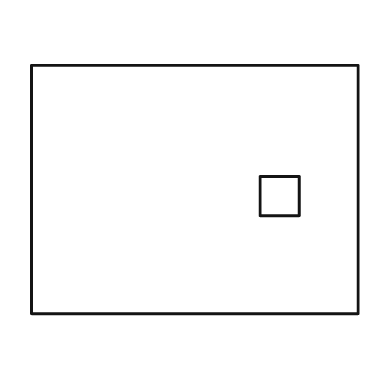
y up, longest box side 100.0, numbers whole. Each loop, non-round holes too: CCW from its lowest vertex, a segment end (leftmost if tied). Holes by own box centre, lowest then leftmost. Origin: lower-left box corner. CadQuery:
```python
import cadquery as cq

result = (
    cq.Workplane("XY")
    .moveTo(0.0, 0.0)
    .lineTo(100.0, 0.0)
    .lineTo(100.0, 76.0)
    .lineTo(0.0, 76.0)
    .close()
    .moveTo(70.0, 30.0)
    .lineTo(82.0, 30.0)
    .lineTo(82.0, 42.0)
    .lineTo(70.0, 42.0)
    .close()
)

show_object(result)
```